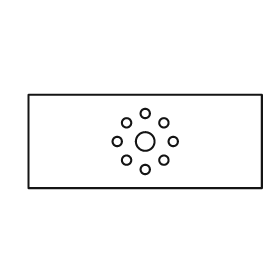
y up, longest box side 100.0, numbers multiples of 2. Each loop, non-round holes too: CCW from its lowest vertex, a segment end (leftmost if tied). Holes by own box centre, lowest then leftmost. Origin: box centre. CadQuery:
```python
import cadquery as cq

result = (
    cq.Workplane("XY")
    .moveTo(-50.0, -20.0)
    .lineTo(50.0, -20.0)
    .lineTo(50.0, 20.0)
    .lineTo(-50.0, 20.0)
    .close()
    .moveTo(0.0, -12.0)
    .circle(2.0)
    .moveTo(-8.0, -8.0)
    .circle(2.0)
    .moveTo(8.0, -8.0)
    .circle(2.0)
    .moveTo(-12.0, 0.0)
    .circle(2.0)
    .moveTo(0.0, 0.0)
    .circle(4.0)
    .moveTo(12.0, 0.0)
    .circle(2.0)
    .moveTo(-8.0, 8.0)
    .circle(2.0)
    .moveTo(8.0, 8.0)
    .circle(2.0)
    .moveTo(0.0, 12.0)
    .circle(2.0)
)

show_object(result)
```